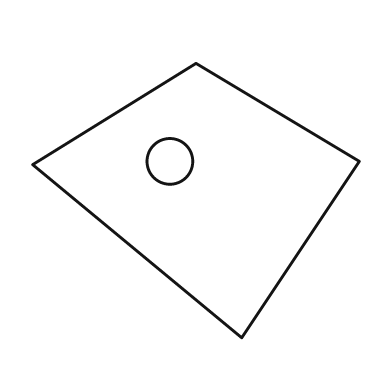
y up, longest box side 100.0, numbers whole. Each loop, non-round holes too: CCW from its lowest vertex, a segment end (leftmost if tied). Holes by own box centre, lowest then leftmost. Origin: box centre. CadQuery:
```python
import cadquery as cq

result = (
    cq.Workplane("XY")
    .moveTo(14.0, -42.0)
    .lineTo(50.0, 12.0)
    .lineTo(0.0, 42.0)
    .lineTo(-50.0, 11.0)
    .close()
    .moveTo(-8.0, 12.0)
    .circle(7.0)
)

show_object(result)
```